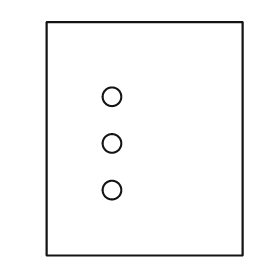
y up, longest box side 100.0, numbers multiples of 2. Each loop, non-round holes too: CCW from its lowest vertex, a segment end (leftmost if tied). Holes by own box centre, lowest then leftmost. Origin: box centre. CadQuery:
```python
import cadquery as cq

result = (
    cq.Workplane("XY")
    .moveTo(-42.0, -50.0)
    .lineTo(42.0, -50.0)
    .lineTo(42.0, 50.0)
    .lineTo(-42.0, 50.0)
    .close()
    .moveTo(-14.0, -22.0)
    .circle(4.0)
    .moveTo(-14.0, -2.0)
    .circle(4.0)
    .moveTo(-14.0, 18.0)
    .circle(4.0)
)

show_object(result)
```